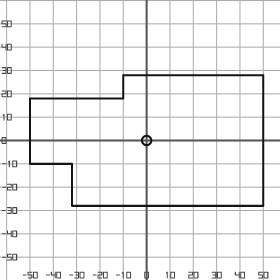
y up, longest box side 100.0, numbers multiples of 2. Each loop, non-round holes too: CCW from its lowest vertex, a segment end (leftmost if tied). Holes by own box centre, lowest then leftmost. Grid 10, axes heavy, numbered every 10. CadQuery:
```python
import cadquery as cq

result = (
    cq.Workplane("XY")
    .moveTo(-32.0, -28.0)
    .lineTo(50.0, -28.0)
    .lineTo(50.0, 28.0)
    .lineTo(-10.0, 28.0)
    .lineTo(-10.0, 18.0)
    .lineTo(-50.0, 18.0)
    .lineTo(-50.0, -10.0)
    .lineTo(-32.0, -10.0)
    .close()
    .moveTo(0.0, 0.0)
    .circle(2.0)
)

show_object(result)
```